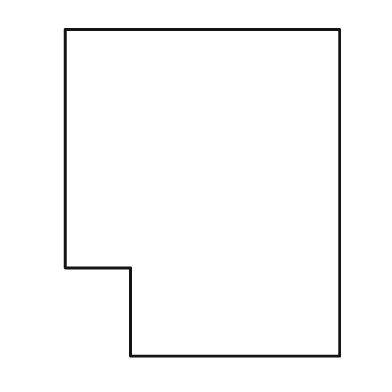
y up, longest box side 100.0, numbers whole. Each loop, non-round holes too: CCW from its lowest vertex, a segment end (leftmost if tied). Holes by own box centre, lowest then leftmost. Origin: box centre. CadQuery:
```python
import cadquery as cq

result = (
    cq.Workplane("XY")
    .moveTo(-22.0, -50.0)
    .lineTo(42.0, -50.0)
    .lineTo(42.0, 50.0)
    .lineTo(-42.0, 50.0)
    .lineTo(-42.0, -23.0)
    .lineTo(-22.0, -23.0)
    .close()
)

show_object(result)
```